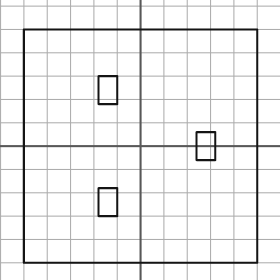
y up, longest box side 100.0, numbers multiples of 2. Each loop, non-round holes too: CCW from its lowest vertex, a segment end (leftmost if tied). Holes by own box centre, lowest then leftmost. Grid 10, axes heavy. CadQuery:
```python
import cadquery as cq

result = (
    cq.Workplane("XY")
    .moveTo(-50.0, -50.0)
    .lineTo(50.0, -50.0)
    .lineTo(50.0, 50.0)
    .lineTo(-50.0, 50.0)
    .close()
    .moveTo(-18.0, -30.0)
    .lineTo(-10.0, -30.0)
    .lineTo(-10.0, -18.0)
    .lineTo(-18.0, -18.0)
    .close()
    .moveTo(24.0, -6.0)
    .lineTo(32.0, -6.0)
    .lineTo(32.0, 6.0)
    .lineTo(24.0, 6.0)
    .close()
    .moveTo(-18.0, 18.0)
    .lineTo(-10.0, 18.0)
    .lineTo(-10.0, 30.0)
    .lineTo(-18.0, 30.0)
    .close()
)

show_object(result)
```